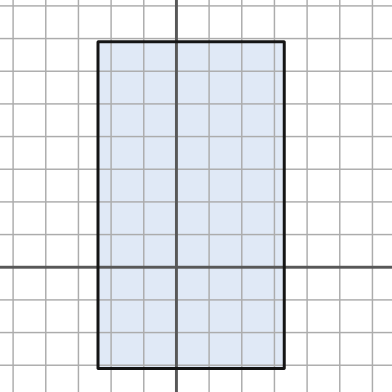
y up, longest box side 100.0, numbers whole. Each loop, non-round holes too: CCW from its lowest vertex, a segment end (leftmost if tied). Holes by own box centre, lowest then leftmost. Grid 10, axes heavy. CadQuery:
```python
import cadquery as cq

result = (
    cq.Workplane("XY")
    .moveTo(-24.0, -31.0)
    .lineTo(33.0, -31.0)
    .lineTo(33.0, 69.0)
    .lineTo(-24.0, 69.0)
    .close()
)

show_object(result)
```